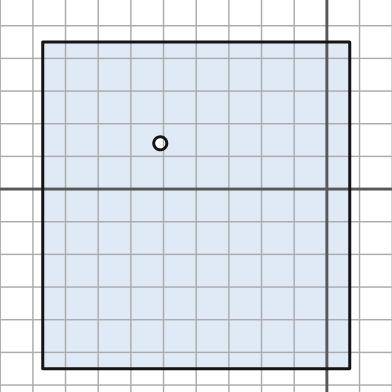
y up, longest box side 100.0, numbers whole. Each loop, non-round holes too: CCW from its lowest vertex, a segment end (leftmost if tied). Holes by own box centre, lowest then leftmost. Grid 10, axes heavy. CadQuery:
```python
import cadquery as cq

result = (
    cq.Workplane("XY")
    .moveTo(-87.0, -55.0)
    .lineTo(7.0, -55.0)
    .lineTo(7.0, 45.0)
    .lineTo(-87.0, 45.0)
    .close()
    .moveTo(-51.0, 14.0)
    .circle(2.0)
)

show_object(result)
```